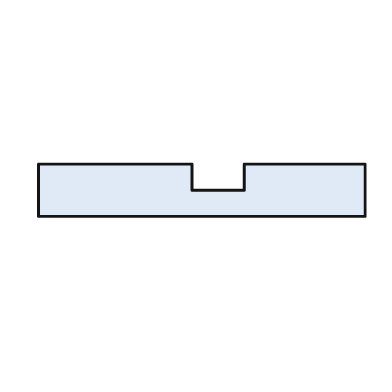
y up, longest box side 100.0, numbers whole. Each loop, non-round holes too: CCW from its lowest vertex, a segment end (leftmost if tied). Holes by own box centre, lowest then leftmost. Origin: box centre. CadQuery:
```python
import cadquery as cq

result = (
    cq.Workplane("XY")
    .moveTo(-50.0, -8.0)
    .lineTo(50.0, -8.0)
    .lineTo(50.0, 8.0)
    .lineTo(13.0, 8.0)
    .lineTo(13.0, 0.0)
    .lineTo(-3.0, 0.0)
    .lineTo(-3.0, 8.0)
    .lineTo(-50.0, 8.0)
    .close()
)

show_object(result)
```